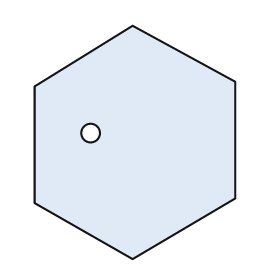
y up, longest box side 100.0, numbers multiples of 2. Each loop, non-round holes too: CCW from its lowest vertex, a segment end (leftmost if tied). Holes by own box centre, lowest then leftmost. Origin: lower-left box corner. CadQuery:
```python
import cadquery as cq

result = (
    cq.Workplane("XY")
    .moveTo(42.0, 0.0)
    .lineTo(86.0, 26.0)
    .lineTo(86.0, 76.0)
    .lineTo(42.0, 100.0)
    .lineTo(0.0, 74.0)
    .lineTo(0.0, 24.0)
    .close()
    .moveTo(24.0, 54.0)
    .circle(4.0)
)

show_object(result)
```